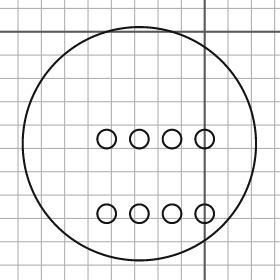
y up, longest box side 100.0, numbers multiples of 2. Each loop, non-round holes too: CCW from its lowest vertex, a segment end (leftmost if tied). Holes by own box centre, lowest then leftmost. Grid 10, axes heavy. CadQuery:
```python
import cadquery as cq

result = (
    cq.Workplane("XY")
    .moveTo(-28.0, -48.0)
    .circle(50.0)
    .moveTo(-42.0, -78.0)
    .circle(4.0)
    .moveTo(-28.0, -78.0)
    .circle(4.0)
    .moveTo(-14.0, -78.0)
    .circle(4.0)
    .moveTo(0.0, -78.0)
    .circle(4.0)
    .moveTo(-42.0, -46.0)
    .circle(4.0)
    .moveTo(-28.0, -46.0)
    .circle(4.0)
    .moveTo(-14.0, -46.0)
    .circle(4.0)
    .moveTo(0.0, -46.0)
    .circle(4.0)
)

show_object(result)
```